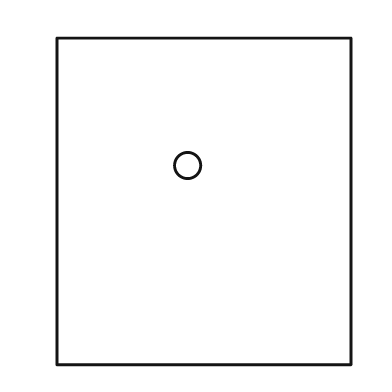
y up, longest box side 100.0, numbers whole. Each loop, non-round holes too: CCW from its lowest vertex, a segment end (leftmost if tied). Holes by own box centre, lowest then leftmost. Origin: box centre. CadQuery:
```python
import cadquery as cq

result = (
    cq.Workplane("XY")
    .moveTo(-45.0, -50.0)
    .lineTo(45.0, -50.0)
    .lineTo(45.0, 50.0)
    .lineTo(-45.0, 50.0)
    .close()
    .moveTo(-5.0, 11.0)
    .circle(4.0)
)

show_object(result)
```